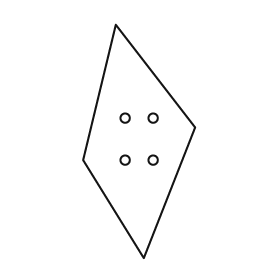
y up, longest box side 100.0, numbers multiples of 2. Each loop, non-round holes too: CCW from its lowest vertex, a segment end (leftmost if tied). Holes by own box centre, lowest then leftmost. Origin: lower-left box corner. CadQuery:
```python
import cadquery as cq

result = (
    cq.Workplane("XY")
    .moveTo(26.0, 0.0)
    .lineTo(48.0, 56.0)
    .lineTo(14.0, 100.0)
    .lineTo(0.0, 42.0)
    .close()
    .moveTo(18.0, 42.0)
    .circle(2.0)
    .moveTo(30.0, 42.0)
    .circle(2.0)
    .moveTo(18.0, 60.0)
    .circle(2.0)
    .moveTo(30.0, 60.0)
    .circle(2.0)
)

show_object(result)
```